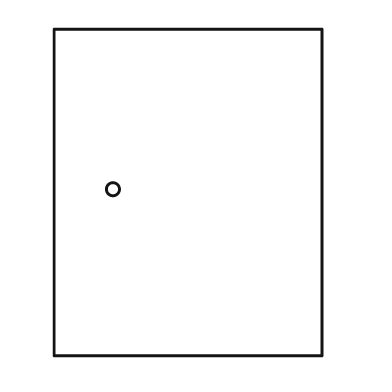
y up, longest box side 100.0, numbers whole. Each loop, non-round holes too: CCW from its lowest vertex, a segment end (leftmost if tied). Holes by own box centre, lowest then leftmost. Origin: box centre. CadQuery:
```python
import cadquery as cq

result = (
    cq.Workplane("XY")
    .moveTo(-41.0, -50.0)
    .lineTo(41.0, -50.0)
    .lineTo(41.0, 50.0)
    .lineTo(-41.0, 50.0)
    .close()
    .moveTo(-23.0, 1.0)
    .circle(2.0)
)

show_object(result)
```